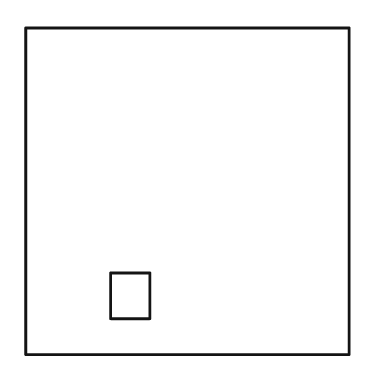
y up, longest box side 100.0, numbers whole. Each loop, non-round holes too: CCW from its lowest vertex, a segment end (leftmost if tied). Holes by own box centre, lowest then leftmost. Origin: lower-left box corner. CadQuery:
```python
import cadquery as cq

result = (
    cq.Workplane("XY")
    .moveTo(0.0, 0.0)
    .lineTo(99.0, 0.0)
    .lineTo(99.0, 100.0)
    .lineTo(0.0, 100.0)
    .close()
    .moveTo(26.0, 11.0)
    .lineTo(38.0, 11.0)
    .lineTo(38.0, 25.0)
    .lineTo(26.0, 25.0)
    .close()
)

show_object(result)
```